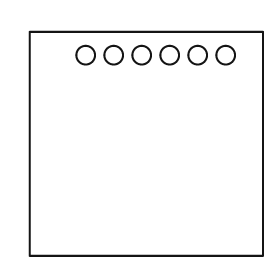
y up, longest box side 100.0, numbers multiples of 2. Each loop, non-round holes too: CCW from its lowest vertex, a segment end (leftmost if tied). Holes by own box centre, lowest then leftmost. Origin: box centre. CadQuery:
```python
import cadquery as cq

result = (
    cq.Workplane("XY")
    .moveTo(-50.0, -48.0)
    .lineTo(50.0, -48.0)
    .lineTo(50.0, 48.0)
    .lineTo(-50.0, 48.0)
    .close()
    .moveTo(-26.0, 38.0)
    .circle(4.0)
    .moveTo(-14.0, 38.0)
    .circle(4.0)
    .moveTo(-2.0, 38.0)
    .circle(4.0)
    .moveTo(10.0, 38.0)
    .circle(4.0)
    .moveTo(22.0, 38.0)
    .circle(4.0)
    .moveTo(34.0, 38.0)
    .circle(4.0)
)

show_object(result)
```